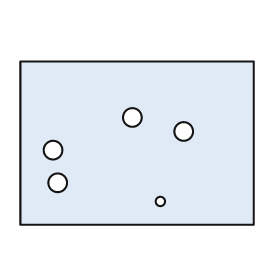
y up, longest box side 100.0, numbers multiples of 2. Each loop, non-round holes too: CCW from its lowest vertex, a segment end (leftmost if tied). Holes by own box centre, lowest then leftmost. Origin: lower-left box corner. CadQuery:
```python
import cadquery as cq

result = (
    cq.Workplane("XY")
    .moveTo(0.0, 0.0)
    .lineTo(100.0, 0.0)
    .lineTo(100.0, 70.0)
    .lineTo(0.0, 70.0)
    .close()
    .moveTo(60.0, 10.0)
    .circle(2.0)
    .moveTo(16.0, 18.0)
    .circle(4.0)
    .moveTo(14.0, 32.0)
    .circle(4.0)
    .moveTo(70.0, 40.0)
    .circle(4.0)
    .moveTo(48.0, 46.0)
    .circle(4.0)
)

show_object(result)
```